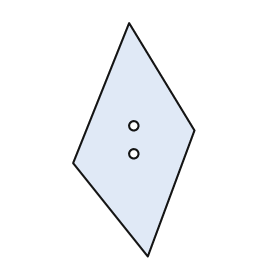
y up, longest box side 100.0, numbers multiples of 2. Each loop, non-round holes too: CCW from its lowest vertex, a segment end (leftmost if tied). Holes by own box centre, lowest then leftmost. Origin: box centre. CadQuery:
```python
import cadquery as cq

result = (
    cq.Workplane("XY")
    .moveTo(6.0, -50.0)
    .lineTo(26.0, 4.0)
    .lineTo(-2.0, 50.0)
    .lineTo(-26.0, -10.0)
    .close()
    .moveTo(0.0, -6.0)
    .circle(2.0)
    .moveTo(0.0, 6.0)
    .circle(2.0)
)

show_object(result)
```